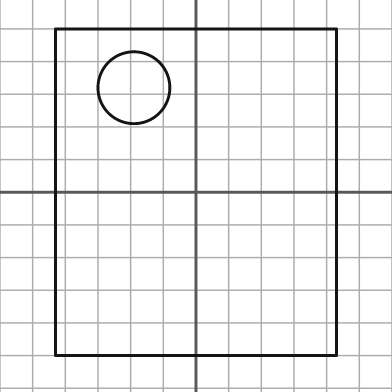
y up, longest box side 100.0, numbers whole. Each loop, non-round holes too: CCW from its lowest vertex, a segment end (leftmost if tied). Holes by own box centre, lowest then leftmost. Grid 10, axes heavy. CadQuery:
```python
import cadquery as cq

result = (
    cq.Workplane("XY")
    .moveTo(-43.0, -50.0)
    .lineTo(43.0, -50.0)
    .lineTo(43.0, 50.0)
    .lineTo(-43.0, 50.0)
    .close()
    .moveTo(-19.0, 32.0)
    .circle(11.0)
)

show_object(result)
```